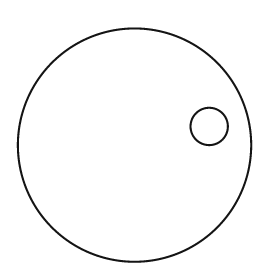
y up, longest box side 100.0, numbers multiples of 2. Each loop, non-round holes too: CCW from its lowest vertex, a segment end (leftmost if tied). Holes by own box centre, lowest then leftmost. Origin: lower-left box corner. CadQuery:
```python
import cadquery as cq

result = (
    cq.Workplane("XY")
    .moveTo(50.0, 50.0)
    .circle(50.0)
    .moveTo(82.0, 58.0)
    .circle(8.0)
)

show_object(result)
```